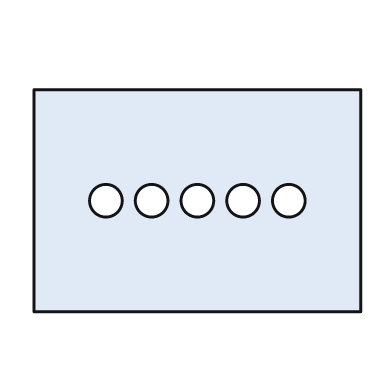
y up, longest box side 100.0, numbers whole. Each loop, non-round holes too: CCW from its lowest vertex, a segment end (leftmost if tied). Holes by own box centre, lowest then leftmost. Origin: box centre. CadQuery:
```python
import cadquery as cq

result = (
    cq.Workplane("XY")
    .moveTo(-50.0, -34.0)
    .lineTo(50.0, -34.0)
    .lineTo(50.0, 34.0)
    .lineTo(-50.0, 34.0)
    .close()
    .moveTo(-28.0, 0.0)
    .circle(5.0)
    .moveTo(-14.0, 0.0)
    .circle(5.0)
    .moveTo(0.0, 0.0)
    .circle(5.0)
    .moveTo(14.0, 0.0)
    .circle(5.0)
    .moveTo(28.0, 0.0)
    .circle(5.0)
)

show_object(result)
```